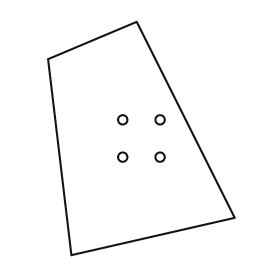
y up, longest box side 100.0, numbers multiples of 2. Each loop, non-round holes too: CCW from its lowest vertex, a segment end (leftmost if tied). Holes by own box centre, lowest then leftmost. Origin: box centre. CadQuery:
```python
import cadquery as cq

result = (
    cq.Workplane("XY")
    .moveTo(-30.0, -50.0)
    .lineTo(40.0, -34.0)
    .lineTo(-2.0, 50.0)
    .lineTo(-40.0, 34.0)
    .close()
    .moveTo(-8.0, -8.0)
    .circle(2.0)
    .moveTo(8.0, -8.0)
    .circle(2.0)
    .moveTo(-8.0, 8.0)
    .circle(2.0)
    .moveTo(8.0, 8.0)
    .circle(2.0)
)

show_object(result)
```